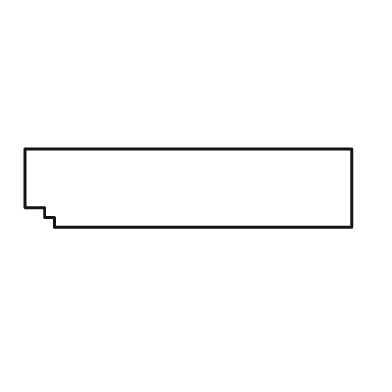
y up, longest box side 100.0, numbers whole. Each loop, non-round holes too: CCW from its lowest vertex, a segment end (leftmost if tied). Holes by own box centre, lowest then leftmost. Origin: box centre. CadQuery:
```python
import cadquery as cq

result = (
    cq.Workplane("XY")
    .moveTo(-41.0, -12.0)
    .lineTo(50.0, -12.0)
    .lineTo(50.0, 12.0)
    .lineTo(-50.0, 12.0)
    .lineTo(-50.0, -6.0)
    .lineTo(-44.0, -6.0)
    .lineTo(-44.0, -9.0)
    .lineTo(-41.0, -9.0)
    .close()
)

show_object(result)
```